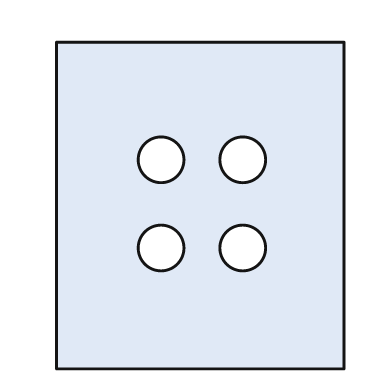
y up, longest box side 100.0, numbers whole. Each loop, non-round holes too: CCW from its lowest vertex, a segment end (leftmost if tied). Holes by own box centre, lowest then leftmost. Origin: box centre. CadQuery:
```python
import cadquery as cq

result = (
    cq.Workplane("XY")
    .moveTo(-44.0, -50.0)
    .lineTo(44.0, -50.0)
    .lineTo(44.0, 50.0)
    .lineTo(-44.0, 50.0)
    .close()
    .moveTo(-12.0, -13.0)
    .circle(7.0)
    .moveTo(13.0, -13.0)
    .circle(7.0)
    .moveTo(-12.0, 14.0)
    .circle(7.0)
    .moveTo(13.0, 14.0)
    .circle(7.0)
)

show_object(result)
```